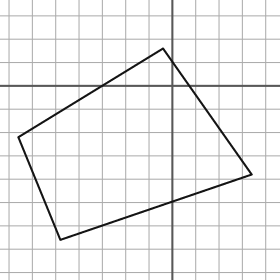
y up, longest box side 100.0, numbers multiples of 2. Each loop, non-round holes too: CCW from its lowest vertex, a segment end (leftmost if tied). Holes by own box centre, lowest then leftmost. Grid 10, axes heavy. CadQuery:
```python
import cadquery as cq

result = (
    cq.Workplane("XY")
    .moveTo(-48.0, -66.0)
    .lineTo(34.0, -38.0)
    .lineTo(-4.0, 16.0)
    .lineTo(-66.0, -22.0)
    .close()
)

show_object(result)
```